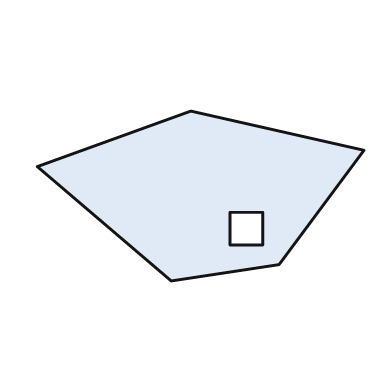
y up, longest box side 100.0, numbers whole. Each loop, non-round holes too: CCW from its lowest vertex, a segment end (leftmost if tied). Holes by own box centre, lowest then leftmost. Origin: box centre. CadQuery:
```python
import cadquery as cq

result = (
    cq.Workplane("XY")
    .moveTo(-9.0, -26.0)
    .lineTo(24.0, -21.0)
    .lineTo(50.0, 14.0)
    .lineTo(-3.0, 26.0)
    .lineTo(-50.0, 9.0)
    .close()
    .moveTo(9.0, -15.0)
    .lineTo(19.0, -15.0)
    .lineTo(19.0, -5.0)
    .lineTo(9.0, -5.0)
    .close()
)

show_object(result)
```